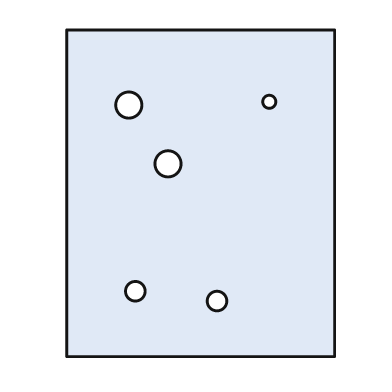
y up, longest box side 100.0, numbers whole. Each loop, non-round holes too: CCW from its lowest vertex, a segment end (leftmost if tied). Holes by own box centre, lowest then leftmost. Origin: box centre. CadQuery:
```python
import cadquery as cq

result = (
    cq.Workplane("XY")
    .moveTo(-41.0, -50.0)
    .lineTo(41.0, -50.0)
    .lineTo(41.0, 50.0)
    .lineTo(-41.0, 50.0)
    .close()
    .moveTo(5.0, -33.0)
    .circle(3.0)
    .moveTo(-20.0, -30.0)
    .circle(3.0)
    .moveTo(-10.0, 9.0)
    .circle(4.0)
    .moveTo(-22.0, 27.0)
    .circle(4.0)
    .moveTo(21.0, 28.0)
    .circle(2.0)
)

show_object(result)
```